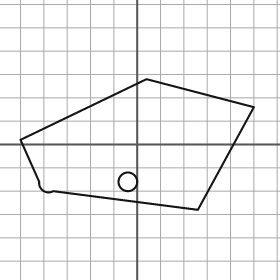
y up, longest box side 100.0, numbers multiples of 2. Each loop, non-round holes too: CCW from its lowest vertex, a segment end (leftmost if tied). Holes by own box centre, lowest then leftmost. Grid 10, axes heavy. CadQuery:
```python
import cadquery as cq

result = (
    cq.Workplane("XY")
    .moveTo(26.0, -28.0)
    .lineTo(50.0, 16.0)
    .lineTo(4.0, 28.0)
    .lineTo(-50.0, 2.0)
    .lineTo(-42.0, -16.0)
    .threePointArc((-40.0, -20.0), (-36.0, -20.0))
    .close()
    .moveTo(-4.0, -16.0)
    .circle(4.0)
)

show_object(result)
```